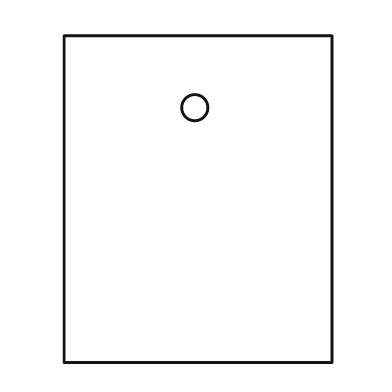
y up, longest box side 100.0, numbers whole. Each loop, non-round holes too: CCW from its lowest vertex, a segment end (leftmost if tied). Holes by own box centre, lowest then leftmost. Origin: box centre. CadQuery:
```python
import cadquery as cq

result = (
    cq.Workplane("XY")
    .moveTo(-41.0, -50.0)
    .lineTo(41.0, -50.0)
    .lineTo(41.0, 50.0)
    .lineTo(-41.0, 50.0)
    .close()
    .moveTo(-1.0, 28.0)
    .circle(4.0)
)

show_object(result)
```